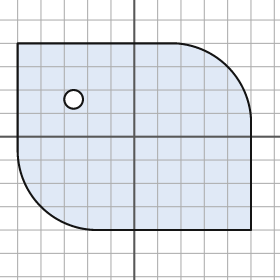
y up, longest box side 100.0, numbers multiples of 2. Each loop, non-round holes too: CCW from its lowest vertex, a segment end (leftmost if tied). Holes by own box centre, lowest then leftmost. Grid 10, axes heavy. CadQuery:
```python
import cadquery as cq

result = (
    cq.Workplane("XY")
    .moveTo(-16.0, -40.0)
    .lineTo(50.0, -40.0)
    .lineTo(50.0, 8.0)
    .threePointArc((40.0, 30.0), (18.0, 40.0))
    .lineTo(-50.0, 40.0)
    .lineTo(-50.0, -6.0)
    .threePointArc((-40.0, -30.0), (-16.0, -40.0))
    .close()
    .moveTo(-26.0, 16.0)
    .circle(4.0)
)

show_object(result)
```